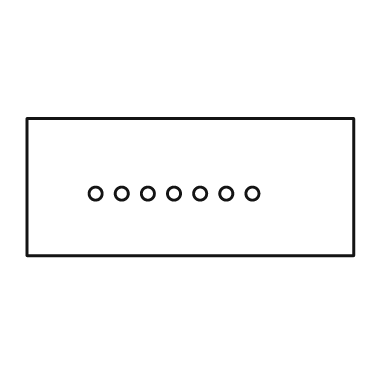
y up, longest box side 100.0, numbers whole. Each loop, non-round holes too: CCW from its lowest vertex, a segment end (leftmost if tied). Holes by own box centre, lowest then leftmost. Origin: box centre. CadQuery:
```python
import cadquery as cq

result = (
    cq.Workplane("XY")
    .moveTo(-50.0, -21.0)
    .lineTo(50.0, -21.0)
    .lineTo(50.0, 21.0)
    .lineTo(-50.0, 21.0)
    .close()
    .moveTo(-29.0, -2.0)
    .circle(2.0)
    .moveTo(-21.0, -2.0)
    .circle(2.0)
    .moveTo(-13.0, -2.0)
    .circle(2.0)
    .moveTo(-5.0, -2.0)
    .circle(2.0)
    .moveTo(3.0, -2.0)
    .circle(2.0)
    .moveTo(11.0, -2.0)
    .circle(2.0)
    .moveTo(19.0, -2.0)
    .circle(2.0)
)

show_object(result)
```